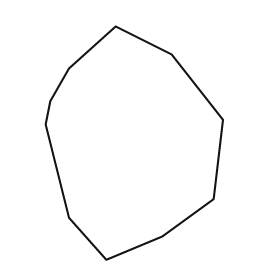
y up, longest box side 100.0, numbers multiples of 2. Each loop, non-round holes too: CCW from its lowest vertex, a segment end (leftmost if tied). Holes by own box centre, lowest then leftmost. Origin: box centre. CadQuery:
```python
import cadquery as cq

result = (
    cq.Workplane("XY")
    .moveTo(-12.0, -50.0)
    .lineTo(12.0, -40.0)
    .lineTo(34.0, -24.0)
    .lineTo(38.0, 10.0)
    .lineTo(16.0, 38.0)
    .lineTo(-8.0, 50.0)
    .lineTo(-28.0, 32.0)
    .lineTo(-36.0, 18.0)
    .lineTo(-38.0, 8.0)
    .lineTo(-28.0, -32.0)
    .close()
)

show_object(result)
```